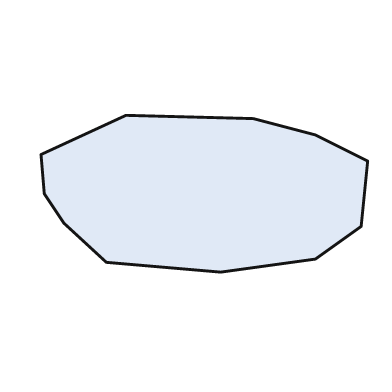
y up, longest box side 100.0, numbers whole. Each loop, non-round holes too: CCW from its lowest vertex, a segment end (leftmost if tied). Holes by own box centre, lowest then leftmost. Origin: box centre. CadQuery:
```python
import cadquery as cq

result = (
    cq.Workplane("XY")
    .moveTo(5.0, -24.0)
    .lineTo(34.0, -20.0)
    .lineTo(48.0, -10.0)
    .lineTo(50.0, 10.0)
    .lineTo(34.0, 18.0)
    .lineTo(15.0, 23.0)
    .lineTo(-24.0, 24.0)
    .lineTo(-50.0, 12.0)
    .lineTo(-49.0, 0.0)
    .lineTo(-43.0, -9.0)
    .lineTo(-30.0, -21.0)
    .close()
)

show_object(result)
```